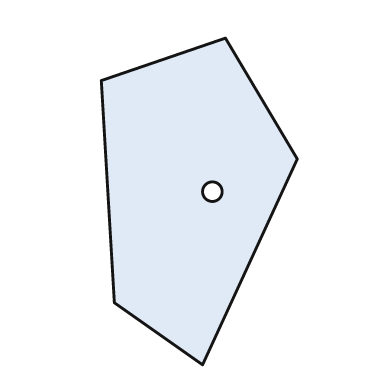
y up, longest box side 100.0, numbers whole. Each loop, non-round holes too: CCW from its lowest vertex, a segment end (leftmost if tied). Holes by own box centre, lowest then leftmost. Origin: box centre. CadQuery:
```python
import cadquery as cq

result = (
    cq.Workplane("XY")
    .moveTo(1.0, -50.0)
    .lineTo(30.0, 13.0)
    .lineTo(8.0, 50.0)
    .lineTo(-30.0, 37.0)
    .lineTo(-26.0, -31.0)
    .close()
    .moveTo(4.0, 3.0)
    .circle(3.0)
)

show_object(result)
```